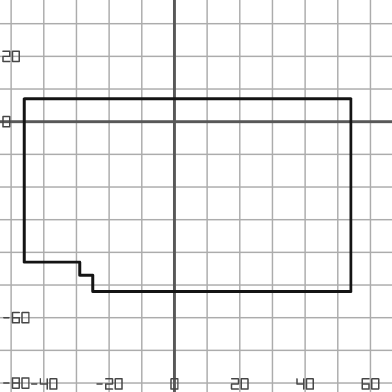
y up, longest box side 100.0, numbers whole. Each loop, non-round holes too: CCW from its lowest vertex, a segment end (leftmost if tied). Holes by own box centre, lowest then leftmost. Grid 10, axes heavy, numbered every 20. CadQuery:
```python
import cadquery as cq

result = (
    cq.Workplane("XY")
    .moveTo(-25.0, -52.0)
    .lineTo(54.0, -52.0)
    .lineTo(54.0, 7.0)
    .lineTo(-46.0, 7.0)
    .lineTo(-46.0, -43.0)
    .lineTo(-29.0, -43.0)
    .lineTo(-29.0, -47.0)
    .lineTo(-25.0, -47.0)
    .close()
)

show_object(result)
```